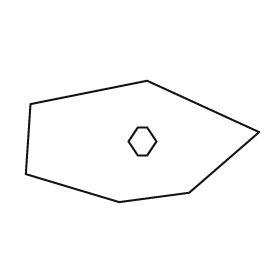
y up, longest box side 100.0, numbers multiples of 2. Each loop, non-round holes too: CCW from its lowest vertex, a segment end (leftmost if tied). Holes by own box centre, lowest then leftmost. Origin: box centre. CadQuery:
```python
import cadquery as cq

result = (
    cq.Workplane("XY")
    .moveTo(-10.0, -26.0)
    .lineTo(20.0, -22.0)
    .lineTo(50.0, 4.0)
    .lineTo(2.0, 26.0)
    .lineTo(-48.0, 16.0)
    .lineTo(-50.0, -14.0)
    .close()
    .moveTo(-2.0, -6.0)
    .lineTo(2.0, -6.0)
    .lineTo(6.0, 0.0)
    .lineTo(2.0, 6.0)
    .lineTo(-2.0, 6.0)
    .lineTo(-6.0, 0.0)
    .close()
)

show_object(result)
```